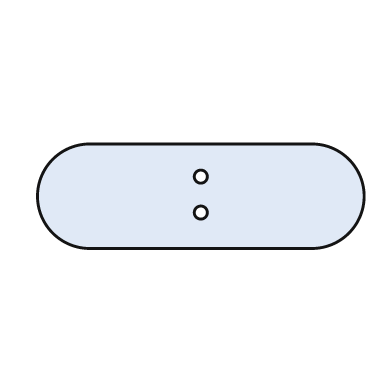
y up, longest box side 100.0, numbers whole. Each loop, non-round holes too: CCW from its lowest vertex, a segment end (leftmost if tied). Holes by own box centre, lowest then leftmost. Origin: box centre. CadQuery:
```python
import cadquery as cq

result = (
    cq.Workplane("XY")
    .moveTo(-34.0, -16.0)
    .lineTo(34.0, -16.0)
    .threePointArc((50.0, 0.0), (34.0, 16.0))
    .lineTo(-34.0, 16.0)
    .threePointArc((-50.0, 0.0), (-34.0, -16.0))
    .close()
    .moveTo(0.0, -5.0)
    .circle(2.0)
    .moveTo(0.0, 6.0)
    .circle(2.0)
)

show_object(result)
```